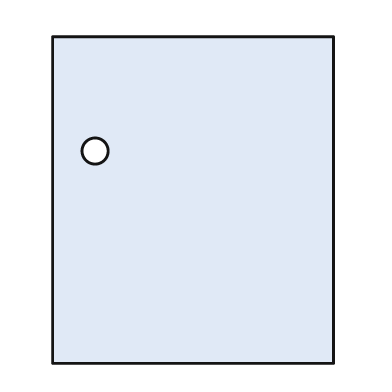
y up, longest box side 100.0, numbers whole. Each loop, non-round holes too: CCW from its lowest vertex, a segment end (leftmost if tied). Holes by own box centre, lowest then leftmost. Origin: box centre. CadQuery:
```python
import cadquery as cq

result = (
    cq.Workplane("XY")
    .moveTo(-43.0, -50.0)
    .lineTo(43.0, -50.0)
    .lineTo(43.0, 50.0)
    .lineTo(-43.0, 50.0)
    .close()
    .moveTo(-30.0, 15.0)
    .circle(4.0)
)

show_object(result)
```